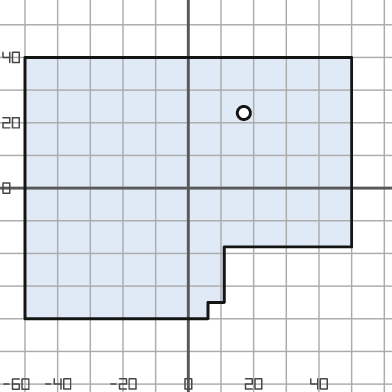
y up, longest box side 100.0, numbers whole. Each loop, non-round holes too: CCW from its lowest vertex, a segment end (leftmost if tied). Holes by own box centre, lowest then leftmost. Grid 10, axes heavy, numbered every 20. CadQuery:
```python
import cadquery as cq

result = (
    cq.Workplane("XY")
    .moveTo(-50.0, -40.0)
    .lineTo(6.0, -40.0)
    .lineTo(6.0, -35.0)
    .lineTo(11.0, -35.0)
    .lineTo(11.0, -18.0)
    .lineTo(50.0, -18.0)
    .lineTo(50.0, 40.0)
    .lineTo(-50.0, 40.0)
    .close()
    .moveTo(17.0, 23.0)
    .circle(2.0)
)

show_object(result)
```